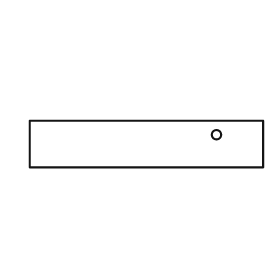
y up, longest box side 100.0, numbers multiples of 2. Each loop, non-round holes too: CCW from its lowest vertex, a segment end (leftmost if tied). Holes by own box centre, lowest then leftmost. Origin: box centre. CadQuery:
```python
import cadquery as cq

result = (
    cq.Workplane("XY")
    .moveTo(-50.0, -10.0)
    .lineTo(50.0, -10.0)
    .lineTo(50.0, 10.0)
    .lineTo(-50.0, 10.0)
    .close()
    .moveTo(30.0, 4.0)
    .circle(2.0)
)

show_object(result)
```